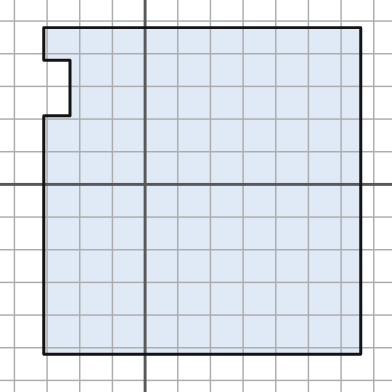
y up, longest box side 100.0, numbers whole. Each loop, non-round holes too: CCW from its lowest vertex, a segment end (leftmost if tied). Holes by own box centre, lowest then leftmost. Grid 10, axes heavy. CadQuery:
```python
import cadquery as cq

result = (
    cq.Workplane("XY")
    .moveTo(-31.0, -52.0)
    .lineTo(66.0, -52.0)
    .lineTo(66.0, 48.0)
    .lineTo(-31.0, 48.0)
    .lineTo(-31.0, 38.0)
    .lineTo(-23.0, 38.0)
    .lineTo(-23.0, 21.0)
    .lineTo(-31.0, 21.0)
    .close()
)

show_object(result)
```